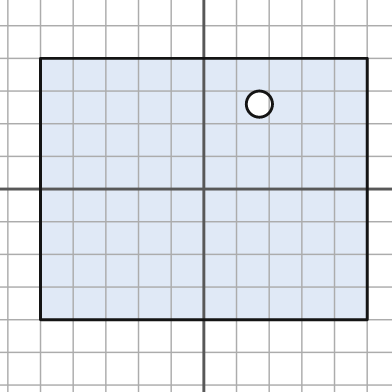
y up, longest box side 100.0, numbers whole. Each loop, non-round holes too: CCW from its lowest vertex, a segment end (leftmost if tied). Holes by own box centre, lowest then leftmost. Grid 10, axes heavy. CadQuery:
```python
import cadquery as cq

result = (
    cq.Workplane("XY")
    .moveTo(-50.0, -40.0)
    .lineTo(50.0, -40.0)
    .lineTo(50.0, 40.0)
    .lineTo(-50.0, 40.0)
    .close()
    .moveTo(17.0, 26.0)
    .circle(4.0)
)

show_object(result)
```